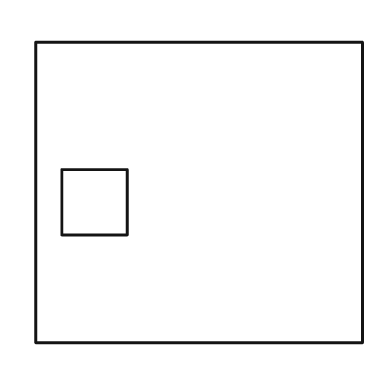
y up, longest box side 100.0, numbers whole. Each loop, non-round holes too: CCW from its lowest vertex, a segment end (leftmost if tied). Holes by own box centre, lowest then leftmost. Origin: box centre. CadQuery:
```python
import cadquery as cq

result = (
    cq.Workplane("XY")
    .moveTo(-50.0, -46.0)
    .lineTo(50.0, -46.0)
    .lineTo(50.0, 46.0)
    .lineTo(-50.0, 46.0)
    .close()
    .moveTo(-42.0, -13.0)
    .lineTo(-22.0, -13.0)
    .lineTo(-22.0, 7.0)
    .lineTo(-42.0, 7.0)
    .close()
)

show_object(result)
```